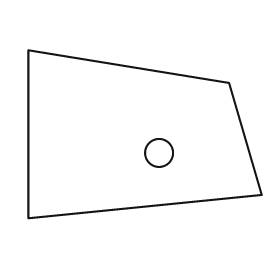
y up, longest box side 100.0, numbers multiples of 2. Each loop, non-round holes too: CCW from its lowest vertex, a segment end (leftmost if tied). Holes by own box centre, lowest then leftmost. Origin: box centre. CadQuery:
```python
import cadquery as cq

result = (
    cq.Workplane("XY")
    .moveTo(-50.0, -36.0)
    .lineTo(50.0, -26.0)
    .lineTo(36.0, 22.0)
    .lineTo(-50.0, 36.0)
    .close()
    .moveTo(6.0, -8.0)
    .circle(6.0)
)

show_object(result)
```